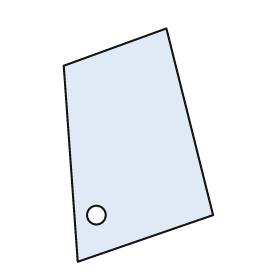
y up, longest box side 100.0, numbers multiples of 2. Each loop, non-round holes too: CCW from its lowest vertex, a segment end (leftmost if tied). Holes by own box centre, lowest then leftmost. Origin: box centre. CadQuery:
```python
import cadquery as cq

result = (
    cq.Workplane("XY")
    .moveTo(-26.0, -50.0)
    .lineTo(32.0, -30.0)
    .lineTo(12.0, 50.0)
    .lineTo(-32.0, 34.0)
    .close()
    .moveTo(-18.0, -30.0)
    .circle(4.0)
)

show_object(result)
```